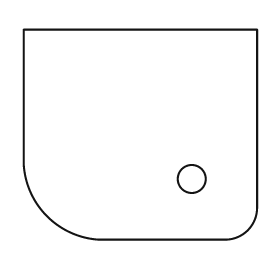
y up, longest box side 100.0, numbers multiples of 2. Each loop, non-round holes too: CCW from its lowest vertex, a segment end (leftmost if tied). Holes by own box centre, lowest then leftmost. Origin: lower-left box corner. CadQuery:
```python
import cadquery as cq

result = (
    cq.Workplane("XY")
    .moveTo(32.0, 0.0)
    .lineTo(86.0, 0.0)
    .threePointArc((96.0, 4.0), (100.0, 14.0))
    .lineTo(100.0, 90.0)
    .lineTo(0.0, 90.0)
    .lineTo(0.0, 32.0)
    .threePointArc((10.0, 10.0), (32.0, 0.0))
    .close()
    .moveTo(72.0, 26.0)
    .circle(6.0)
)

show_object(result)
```